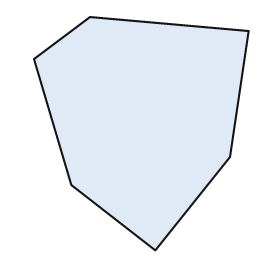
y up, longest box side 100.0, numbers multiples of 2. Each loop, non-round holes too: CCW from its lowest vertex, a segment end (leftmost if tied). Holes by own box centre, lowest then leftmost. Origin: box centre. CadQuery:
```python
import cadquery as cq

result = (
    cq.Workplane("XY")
    .moveTo(6.0, -50.0)
    .lineTo(38.0, -10.0)
    .lineTo(46.0, 44.0)
    .lineTo(-22.0, 50.0)
    .lineTo(-46.0, 32.0)
    .lineTo(-30.0, -22.0)
    .close()
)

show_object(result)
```